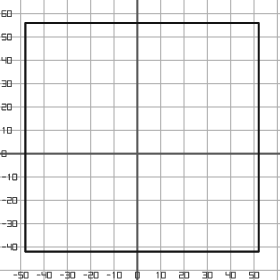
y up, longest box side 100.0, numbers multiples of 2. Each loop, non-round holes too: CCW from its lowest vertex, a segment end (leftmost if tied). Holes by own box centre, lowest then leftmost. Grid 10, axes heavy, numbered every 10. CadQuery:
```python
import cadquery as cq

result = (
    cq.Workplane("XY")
    .moveTo(-48.0, -42.0)
    .lineTo(52.0, -42.0)
    .lineTo(52.0, 56.0)
    .lineTo(-48.0, 56.0)
    .close()
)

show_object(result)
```